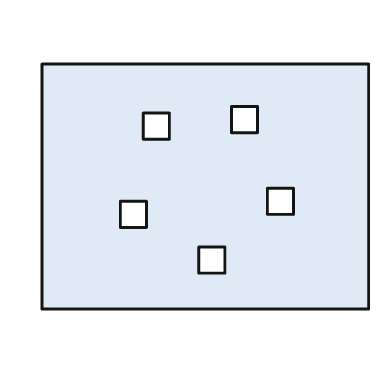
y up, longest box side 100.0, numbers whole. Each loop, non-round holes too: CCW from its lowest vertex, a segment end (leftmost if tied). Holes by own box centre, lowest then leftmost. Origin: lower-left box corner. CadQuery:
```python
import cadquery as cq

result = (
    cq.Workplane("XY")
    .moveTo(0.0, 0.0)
    .lineTo(100.0, 0.0)
    .lineTo(100.0, 75.0)
    .lineTo(0.0, 75.0)
    .close()
    .moveTo(48.0, 11.0)
    .lineTo(56.0, 11.0)
    .lineTo(56.0, 19.0)
    .lineTo(48.0, 19.0)
    .close()
    .moveTo(24.0, 25.0)
    .lineTo(32.0, 25.0)
    .lineTo(32.0, 33.0)
    .lineTo(24.0, 33.0)
    .close()
    .moveTo(69.0, 29.0)
    .lineTo(77.0, 29.0)
    .lineTo(77.0, 37.0)
    .lineTo(69.0, 37.0)
    .close()
    .moveTo(31.0, 52.0)
    .lineTo(39.0, 52.0)
    .lineTo(39.0, 60.0)
    .lineTo(31.0, 60.0)
    .close()
    .moveTo(58.0, 54.0)
    .lineTo(66.0, 54.0)
    .lineTo(66.0, 62.0)
    .lineTo(58.0, 62.0)
    .close()
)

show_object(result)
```